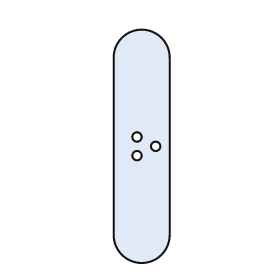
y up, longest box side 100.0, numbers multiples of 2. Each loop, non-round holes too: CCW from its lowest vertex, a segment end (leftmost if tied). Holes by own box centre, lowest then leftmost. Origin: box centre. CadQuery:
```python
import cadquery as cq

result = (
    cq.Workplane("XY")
    .moveTo(-12.0, -38.0)
    .threePointArc((0.0, -50.0), (12.0, -38.0))
    .lineTo(12.0, 38.0)
    .threePointArc((0.0, 50.0), (-12.0, 38.0))
    .close()
    .moveTo(-2.0, -4.0)
    .circle(2.0)
    .moveTo(6.0, 0.0)
    .circle(2.0)
    .moveTo(-2.0, 4.0)
    .circle(2.0)
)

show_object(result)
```